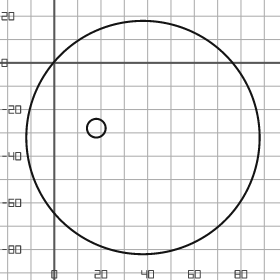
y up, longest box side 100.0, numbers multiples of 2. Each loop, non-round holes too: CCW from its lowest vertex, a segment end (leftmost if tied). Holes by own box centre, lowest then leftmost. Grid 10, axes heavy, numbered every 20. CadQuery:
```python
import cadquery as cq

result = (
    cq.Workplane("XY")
    .moveTo(38.0, -32.0)
    .circle(50.0)
    .moveTo(18.0, -28.0)
    .circle(4.0)
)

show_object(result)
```